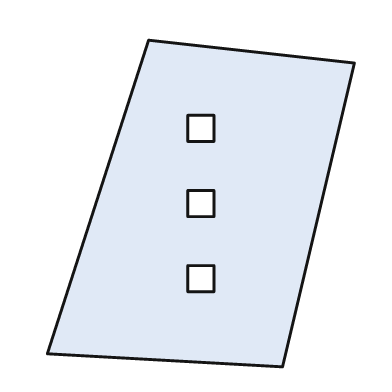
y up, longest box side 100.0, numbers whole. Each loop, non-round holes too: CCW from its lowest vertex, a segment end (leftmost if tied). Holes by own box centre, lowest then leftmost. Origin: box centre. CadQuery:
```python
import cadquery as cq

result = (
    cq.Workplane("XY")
    .moveTo(25.0, -50.0)
    .lineTo(47.0, 43.0)
    .lineTo(-16.0, 50.0)
    .lineTo(-47.0, -46.0)
    .close()
    .moveTo(-4.0, -27.0)
    .lineTo(4.0, -27.0)
    .lineTo(4.0, -19.0)
    .lineTo(-4.0, -19.0)
    .close()
    .moveTo(-4.0, -4.0)
    .lineTo(4.0, -4.0)
    .lineTo(4.0, 4.0)
    .lineTo(-4.0, 4.0)
    .close()
    .moveTo(-4.0, 19.0)
    .lineTo(4.0, 19.0)
    .lineTo(4.0, 27.0)
    .lineTo(-4.0, 27.0)
    .close()
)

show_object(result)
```